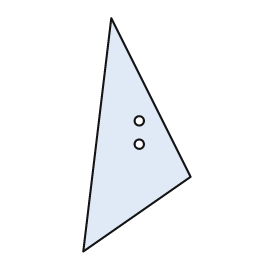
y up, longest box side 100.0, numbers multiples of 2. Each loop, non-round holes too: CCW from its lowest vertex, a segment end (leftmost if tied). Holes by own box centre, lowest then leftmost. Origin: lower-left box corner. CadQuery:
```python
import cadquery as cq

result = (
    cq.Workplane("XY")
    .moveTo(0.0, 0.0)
    .lineTo(46.0, 32.0)
    .lineTo(12.0, 100.0)
    .close()
    .moveTo(24.0, 46.0)
    .circle(2.0)
    .moveTo(24.0, 56.0)
    .circle(2.0)
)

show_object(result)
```